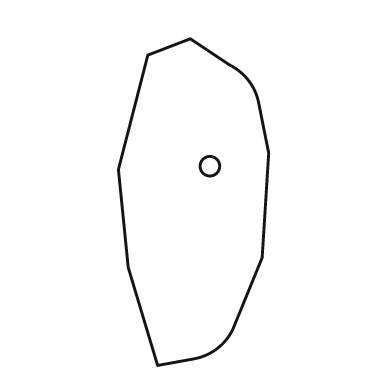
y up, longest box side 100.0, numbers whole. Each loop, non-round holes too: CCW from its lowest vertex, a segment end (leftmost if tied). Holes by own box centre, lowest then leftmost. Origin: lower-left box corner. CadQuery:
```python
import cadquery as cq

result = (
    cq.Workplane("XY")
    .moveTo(12.0, 0.0)
    .lineTo(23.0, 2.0)
    .threePointArc((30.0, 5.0), (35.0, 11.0))
    .lineTo(44.0, 33.0)
    .lineTo(46.0, 65.0)
    .lineTo(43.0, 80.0)
    .threePointArc((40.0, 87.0), (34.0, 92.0))
    .lineTo(22.0, 100.0)
    .lineTo(9.0, 95.0)
    .lineTo(0.0, 60.0)
    .lineTo(3.0, 30.0)
    .close()
    .moveTo(28.0, 61.0)
    .circle(3.0)
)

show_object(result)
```